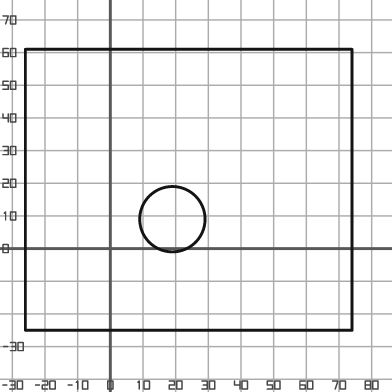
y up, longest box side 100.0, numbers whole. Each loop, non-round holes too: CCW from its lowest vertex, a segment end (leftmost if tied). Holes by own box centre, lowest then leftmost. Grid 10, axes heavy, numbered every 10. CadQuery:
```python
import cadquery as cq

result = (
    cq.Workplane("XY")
    .moveTo(-26.0, -25.0)
    .lineTo(74.0, -25.0)
    .lineTo(74.0, 61.0)
    .lineTo(-26.0, 61.0)
    .close()
    .moveTo(19.0, 9.0)
    .circle(10.0)
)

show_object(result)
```